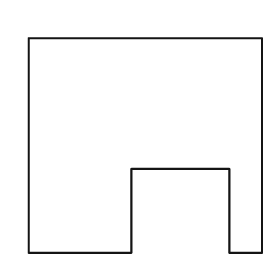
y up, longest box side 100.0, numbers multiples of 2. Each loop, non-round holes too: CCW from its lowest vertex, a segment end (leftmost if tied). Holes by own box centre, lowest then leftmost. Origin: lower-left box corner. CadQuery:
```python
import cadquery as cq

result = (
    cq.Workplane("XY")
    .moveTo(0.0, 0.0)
    .lineTo(44.0, 0.0)
    .lineTo(44.0, 36.0)
    .lineTo(86.0, 36.0)
    .lineTo(86.0, 0.0)
    .lineTo(100.0, 0.0)
    .lineTo(100.0, 92.0)
    .lineTo(0.0, 92.0)
    .close()
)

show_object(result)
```